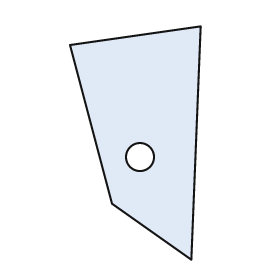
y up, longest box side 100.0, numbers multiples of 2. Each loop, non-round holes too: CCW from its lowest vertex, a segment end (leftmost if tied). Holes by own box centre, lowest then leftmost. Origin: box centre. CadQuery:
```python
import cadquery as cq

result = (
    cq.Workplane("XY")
    .moveTo(24.0, -50.0)
    .lineTo(28.0, 50.0)
    .lineTo(-28.0, 42.0)
    .lineTo(-10.0, -26.0)
    .close()
    .moveTo(2.0, -6.0)
    .circle(6.0)
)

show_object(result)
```